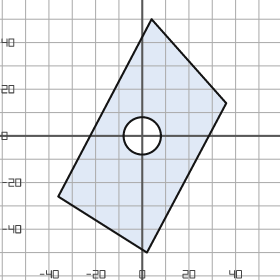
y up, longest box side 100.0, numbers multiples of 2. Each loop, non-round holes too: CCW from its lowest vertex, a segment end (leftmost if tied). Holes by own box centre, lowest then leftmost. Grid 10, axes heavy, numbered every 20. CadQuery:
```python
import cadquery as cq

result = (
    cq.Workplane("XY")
    .moveTo(2.0, -50.0)
    .lineTo(36.0, 14.0)
    .lineTo(4.0, 50.0)
    .lineTo(-36.0, -26.0)
    .close()
    .moveTo(0.0, 0.0)
    .circle(8.0)
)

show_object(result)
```